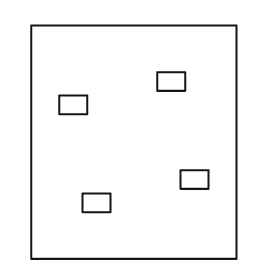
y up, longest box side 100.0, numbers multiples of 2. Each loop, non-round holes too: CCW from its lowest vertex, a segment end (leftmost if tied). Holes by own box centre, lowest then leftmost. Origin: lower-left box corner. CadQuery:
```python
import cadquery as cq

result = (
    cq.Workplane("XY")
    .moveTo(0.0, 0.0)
    .lineTo(88.0, 0.0)
    .lineTo(88.0, 100.0)
    .lineTo(0.0, 100.0)
    .close()
    .moveTo(22.0, 20.0)
    .lineTo(34.0, 20.0)
    .lineTo(34.0, 28.0)
    .lineTo(22.0, 28.0)
    .close()
    .moveTo(64.0, 30.0)
    .lineTo(76.0, 30.0)
    .lineTo(76.0, 38.0)
    .lineTo(64.0, 38.0)
    .close()
    .moveTo(12.0, 62.0)
    .lineTo(24.0, 62.0)
    .lineTo(24.0, 70.0)
    .lineTo(12.0, 70.0)
    .close()
    .moveTo(54.0, 72.0)
    .lineTo(66.0, 72.0)
    .lineTo(66.0, 80.0)
    .lineTo(54.0, 80.0)
    .close()
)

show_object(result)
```